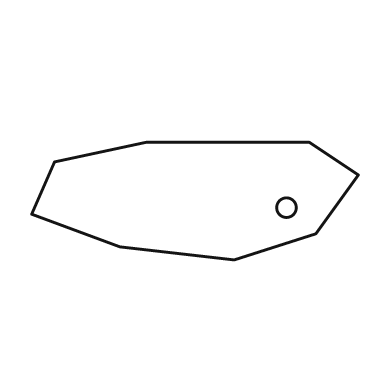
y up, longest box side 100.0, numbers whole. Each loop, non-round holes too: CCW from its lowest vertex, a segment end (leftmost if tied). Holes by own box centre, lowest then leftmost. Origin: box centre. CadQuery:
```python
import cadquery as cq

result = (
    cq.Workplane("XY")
    .moveTo(12.0, -18.0)
    .lineTo(37.0, -10.0)
    .lineTo(50.0, 8.0)
    .lineTo(35.0, 18.0)
    .lineTo(-15.0, 18.0)
    .lineTo(-43.0, 12.0)
    .lineTo(-50.0, -4.0)
    .lineTo(-23.0, -14.0)
    .close()
    .moveTo(28.0, -2.0)
    .circle(3.0)
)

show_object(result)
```